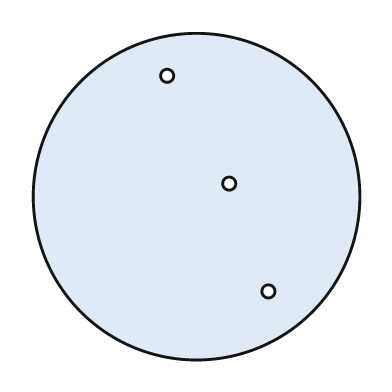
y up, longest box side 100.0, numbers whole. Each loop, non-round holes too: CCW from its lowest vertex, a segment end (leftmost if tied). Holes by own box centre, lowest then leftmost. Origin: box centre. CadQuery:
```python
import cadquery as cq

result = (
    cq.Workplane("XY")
    .moveTo(0.0, 0.0)
    .circle(50.0)
    .moveTo(22.0, -29.0)
    .circle(2.0)
    .moveTo(10.0, 4.0)
    .circle(2.0)
    .moveTo(-9.0, 37.0)
    .circle(2.0)
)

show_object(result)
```